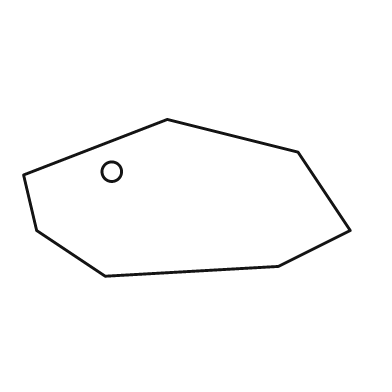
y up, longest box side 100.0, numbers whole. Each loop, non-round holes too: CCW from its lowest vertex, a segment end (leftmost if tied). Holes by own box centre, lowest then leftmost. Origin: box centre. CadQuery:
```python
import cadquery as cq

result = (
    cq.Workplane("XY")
    .moveTo(-25.0, -24.0)
    .lineTo(28.0, -21.0)
    .lineTo(50.0, -10.0)
    .lineTo(34.0, 14.0)
    .lineTo(-6.0, 24.0)
    .lineTo(-50.0, 7.0)
    .lineTo(-46.0, -10.0)
    .close()
    .moveTo(-23.0, 8.0)
    .circle(3.0)
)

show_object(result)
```